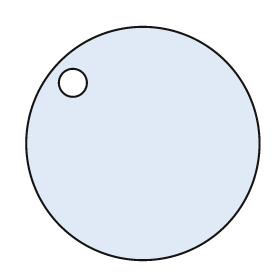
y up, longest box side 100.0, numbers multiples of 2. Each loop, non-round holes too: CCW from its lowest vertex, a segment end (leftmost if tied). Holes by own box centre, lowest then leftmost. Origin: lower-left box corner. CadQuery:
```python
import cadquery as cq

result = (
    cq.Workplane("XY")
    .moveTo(50.0, 50.0)
    .circle(50.0)
    .moveTo(20.0, 76.0)
    .circle(6.0)
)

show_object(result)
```